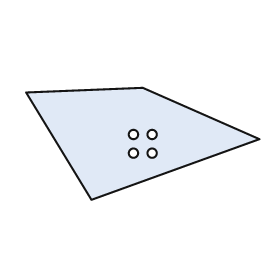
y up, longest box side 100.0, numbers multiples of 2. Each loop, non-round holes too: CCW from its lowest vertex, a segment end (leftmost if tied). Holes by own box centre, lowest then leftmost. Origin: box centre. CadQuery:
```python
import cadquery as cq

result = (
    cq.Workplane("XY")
    .moveTo(-22.0, -24.0)
    .lineTo(50.0, 2.0)
    .lineTo(0.0, 24.0)
    .lineTo(-50.0, 22.0)
    .close()
    .moveTo(-4.0, -4.0)
    .circle(2.0)
    .moveTo(4.0, -4.0)
    .circle(2.0)
    .moveTo(-4.0, 4.0)
    .circle(2.0)
    .moveTo(4.0, 4.0)
    .circle(2.0)
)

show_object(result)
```